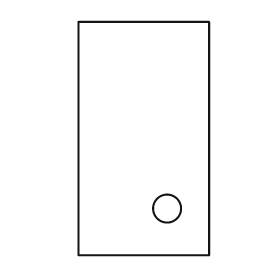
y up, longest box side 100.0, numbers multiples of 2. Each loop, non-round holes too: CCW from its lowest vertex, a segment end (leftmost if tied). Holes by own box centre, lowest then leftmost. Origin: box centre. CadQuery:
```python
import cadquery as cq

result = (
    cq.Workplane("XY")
    .moveTo(-28.0, -50.0)
    .lineTo(28.0, -50.0)
    .lineTo(28.0, 50.0)
    .lineTo(-28.0, 50.0)
    .close()
    .moveTo(10.0, -30.0)
    .circle(6.0)
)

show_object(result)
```